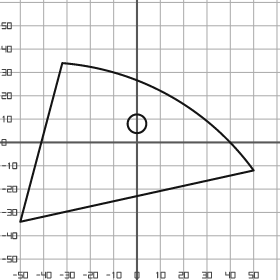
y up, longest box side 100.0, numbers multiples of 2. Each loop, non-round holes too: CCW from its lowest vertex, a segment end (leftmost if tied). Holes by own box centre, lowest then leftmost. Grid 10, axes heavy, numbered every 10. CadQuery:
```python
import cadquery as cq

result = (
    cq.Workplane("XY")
    .moveTo(-50.0, -34.0)
    .lineTo(50.0, -12.0)
    .threePointArc((14.0, 20.0), (-32.0, 34.0))
    .close()
    .moveTo(0.0, 8.0)
    .circle(4.0)
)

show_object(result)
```